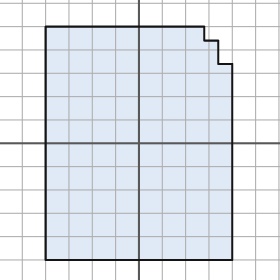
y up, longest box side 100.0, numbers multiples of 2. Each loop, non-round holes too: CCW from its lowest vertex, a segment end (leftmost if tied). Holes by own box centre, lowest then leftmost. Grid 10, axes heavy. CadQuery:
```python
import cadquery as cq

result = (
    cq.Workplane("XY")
    .moveTo(-40.0, -50.0)
    .lineTo(40.0, -50.0)
    .lineTo(40.0, 34.0)
    .lineTo(34.0, 34.0)
    .lineTo(34.0, 44.0)
    .lineTo(28.0, 44.0)
    .lineTo(28.0, 50.0)
    .lineTo(-40.0, 50.0)
    .close()
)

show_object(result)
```